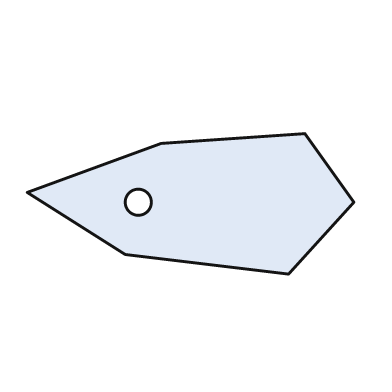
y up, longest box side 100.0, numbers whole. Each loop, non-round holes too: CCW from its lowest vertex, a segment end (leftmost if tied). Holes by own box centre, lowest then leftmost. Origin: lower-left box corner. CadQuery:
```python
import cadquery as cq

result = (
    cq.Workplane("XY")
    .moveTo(80.0, 0.0)
    .lineTo(100.0, 22.0)
    .lineTo(85.0, 43.0)
    .lineTo(41.0, 40.0)
    .lineTo(0.0, 25.0)
    .lineTo(30.0, 6.0)
    .close()
    .moveTo(34.0, 22.0)
    .circle(4.0)
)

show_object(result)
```